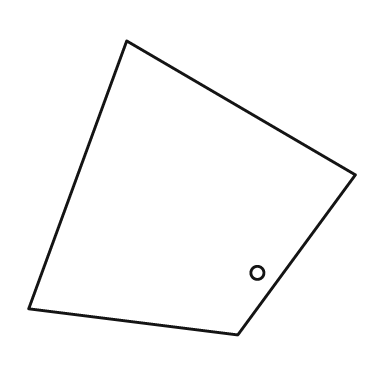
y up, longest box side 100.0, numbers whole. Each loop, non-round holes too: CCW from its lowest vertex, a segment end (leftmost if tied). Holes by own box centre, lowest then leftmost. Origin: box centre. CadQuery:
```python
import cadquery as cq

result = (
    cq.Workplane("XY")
    .moveTo(14.0, -45.0)
    .lineTo(50.0, 4.0)
    .lineTo(-20.0, 45.0)
    .lineTo(-50.0, -37.0)
    .close()
    .moveTo(20.0, -26.0)
    .circle(2.0)
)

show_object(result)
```